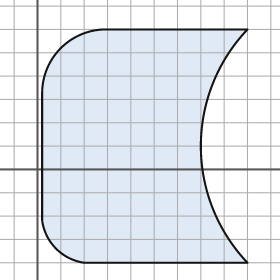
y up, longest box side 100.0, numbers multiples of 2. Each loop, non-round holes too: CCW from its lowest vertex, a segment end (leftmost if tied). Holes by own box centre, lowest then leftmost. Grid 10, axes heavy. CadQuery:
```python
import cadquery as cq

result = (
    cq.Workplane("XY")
    .moveTo(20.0, -40.0)
    .lineTo(90.0, -40.0)
    .threePointArc((70.0, 10.0), (90.0, 60.0))
    .lineTo(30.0, 60.0)
    .threePointArc((10.0, 52.0), (2.0, 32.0))
    .lineTo(2.0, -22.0)
    .threePointArc((8.0, -34.0), (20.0, -40.0))
    .close()
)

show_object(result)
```